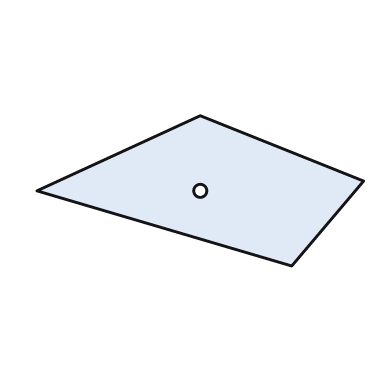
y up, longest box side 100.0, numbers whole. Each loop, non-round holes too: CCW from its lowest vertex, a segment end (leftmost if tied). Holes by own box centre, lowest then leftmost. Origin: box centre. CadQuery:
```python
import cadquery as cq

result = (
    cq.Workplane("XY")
    .moveTo(28.0, -23.0)
    .lineTo(50.0, 3.0)
    .lineTo(0.0, 23.0)
    .lineTo(-50.0, 0.0)
    .close()
    .moveTo(0.0, 0.0)
    .circle(2.0)
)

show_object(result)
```